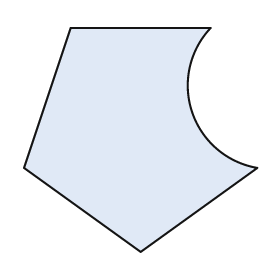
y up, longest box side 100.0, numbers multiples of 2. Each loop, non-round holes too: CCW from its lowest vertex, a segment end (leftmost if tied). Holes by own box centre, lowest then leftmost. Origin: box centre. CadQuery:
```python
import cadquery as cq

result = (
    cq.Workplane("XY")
    .moveTo(0.0, -48.0)
    .lineTo(50.0, -12.0)
    .threePointArc((22.0, 12.0), (30.0, 48.0))
    .lineTo(-30.0, 48.0)
    .lineTo(-50.0, -12.0)
    .close()
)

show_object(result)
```